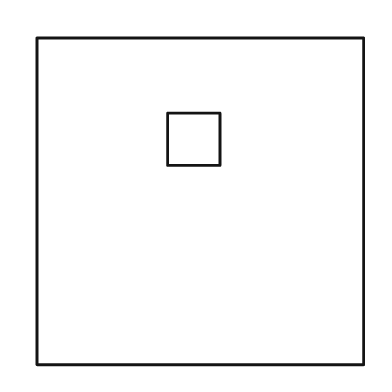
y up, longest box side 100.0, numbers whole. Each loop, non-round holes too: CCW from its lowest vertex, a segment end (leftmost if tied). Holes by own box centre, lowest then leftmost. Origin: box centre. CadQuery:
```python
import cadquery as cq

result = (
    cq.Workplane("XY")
    .moveTo(-50.0, -50.0)
    .lineTo(50.0, -50.0)
    .lineTo(50.0, 50.0)
    .lineTo(-50.0, 50.0)
    .close()
    .moveTo(-10.0, 11.0)
    .lineTo(6.0, 11.0)
    .lineTo(6.0, 27.0)
    .lineTo(-10.0, 27.0)
    .close()
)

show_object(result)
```